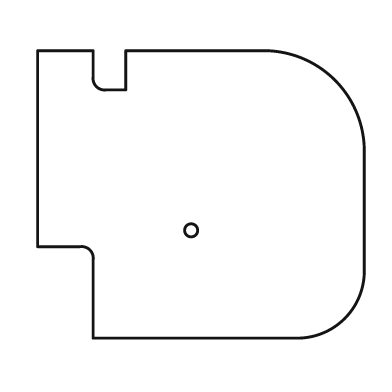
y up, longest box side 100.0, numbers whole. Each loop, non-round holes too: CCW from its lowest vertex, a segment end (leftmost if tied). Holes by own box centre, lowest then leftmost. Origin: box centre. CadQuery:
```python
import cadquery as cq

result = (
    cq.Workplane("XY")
    .moveTo(-33.0, -44.0)
    .lineTo(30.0, -44.0)
    .threePointArc((44.0, -38.0), (50.0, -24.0))
    .lineTo(50.0, 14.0)
    .threePointArc((41.0, 35.0), (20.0, 44.0))
    .lineTo(-23.0, 44.0)
    .lineTo(-23.0, 32.0)
    .lineTo(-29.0, 32.0)
    .threePointArc((-32.0, 33.0), (-33.0, 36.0))
    .lineTo(-33.0, 44.0)
    .lineTo(-50.0, 44.0)
    .lineTo(-50.0, -16.0)
    .lineTo(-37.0, -16.0)
    .threePointArc((-34.0, -17.0), (-33.0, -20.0))
    .close()
    .moveTo(-3.0, -11.0)
    .circle(2.0)
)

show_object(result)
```